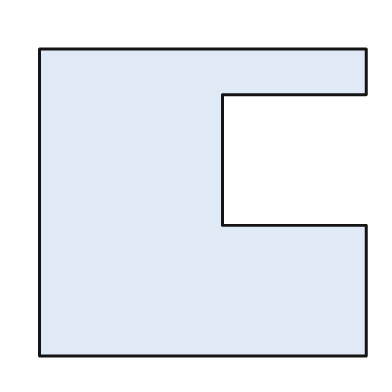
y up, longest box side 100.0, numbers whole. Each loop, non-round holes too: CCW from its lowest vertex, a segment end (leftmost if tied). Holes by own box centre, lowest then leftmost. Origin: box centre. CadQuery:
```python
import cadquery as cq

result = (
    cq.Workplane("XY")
    .moveTo(-50.0, -47.0)
    .lineTo(50.0, -47.0)
    .lineTo(50.0, -7.0)
    .lineTo(6.0, -7.0)
    .lineTo(6.0, 33.0)
    .lineTo(50.0, 33.0)
    .lineTo(50.0, 47.0)
    .lineTo(-50.0, 47.0)
    .close()
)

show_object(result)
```